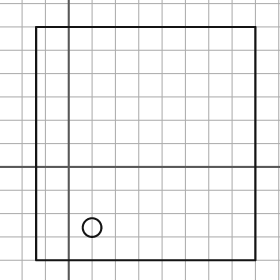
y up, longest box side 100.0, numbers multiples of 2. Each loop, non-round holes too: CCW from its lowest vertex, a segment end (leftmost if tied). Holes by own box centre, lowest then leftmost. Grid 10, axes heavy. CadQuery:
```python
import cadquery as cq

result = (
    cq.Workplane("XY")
    .moveTo(-14.0, -40.0)
    .lineTo(80.0, -40.0)
    .lineTo(80.0, 60.0)
    .lineTo(-14.0, 60.0)
    .close()
    .moveTo(10.0, -26.0)
    .circle(4.0)
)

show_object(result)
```